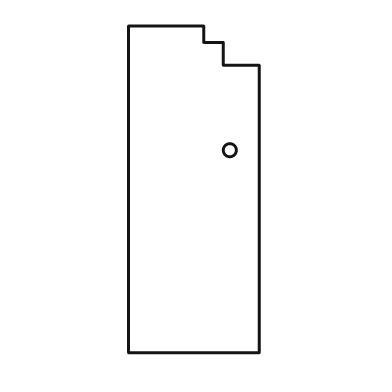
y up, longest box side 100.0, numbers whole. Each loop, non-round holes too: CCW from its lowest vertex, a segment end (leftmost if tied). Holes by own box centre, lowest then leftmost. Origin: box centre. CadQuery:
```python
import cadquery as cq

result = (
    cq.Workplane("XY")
    .moveTo(-20.0, -50.0)
    .lineTo(20.0, -50.0)
    .lineTo(20.0, 38.0)
    .lineTo(9.0, 38.0)
    .lineTo(9.0, 45.0)
    .lineTo(3.0, 45.0)
    .lineTo(3.0, 50.0)
    .lineTo(-20.0, 50.0)
    .close()
    .moveTo(11.0, 12.0)
    .circle(2.0)
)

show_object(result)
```